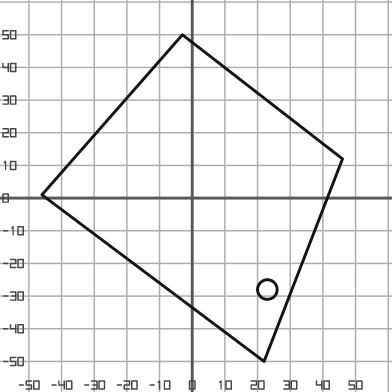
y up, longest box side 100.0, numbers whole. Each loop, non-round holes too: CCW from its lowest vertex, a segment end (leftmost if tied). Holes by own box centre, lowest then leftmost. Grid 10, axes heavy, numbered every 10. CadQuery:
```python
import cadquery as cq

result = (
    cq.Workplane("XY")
    .moveTo(22.0, -50.0)
    .lineTo(46.0, 12.0)
    .lineTo(-3.0, 50.0)
    .lineTo(-46.0, 1.0)
    .close()
    .moveTo(23.0, -28.0)
    .circle(3.0)
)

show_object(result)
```